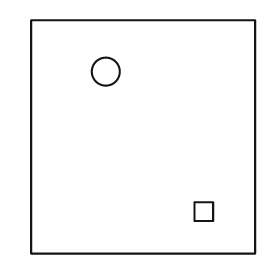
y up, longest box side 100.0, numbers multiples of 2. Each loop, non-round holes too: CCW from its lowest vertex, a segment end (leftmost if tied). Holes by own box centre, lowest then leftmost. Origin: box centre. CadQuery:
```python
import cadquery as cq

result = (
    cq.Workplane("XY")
    .moveTo(-48.0, -50.0)
    .lineTo(48.0, -50.0)
    .lineTo(48.0, 50.0)
    .lineTo(-48.0, 50.0)
    .close()
    .moveTo(22.0, -36.0)
    .lineTo(30.0, -36.0)
    .lineTo(30.0, -28.0)
    .lineTo(22.0, -28.0)
    .close()
    .moveTo(-16.0, 28.0)
    .circle(6.0)
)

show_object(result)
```